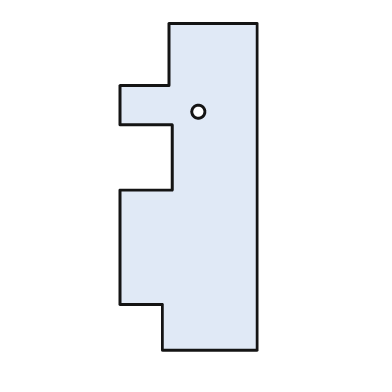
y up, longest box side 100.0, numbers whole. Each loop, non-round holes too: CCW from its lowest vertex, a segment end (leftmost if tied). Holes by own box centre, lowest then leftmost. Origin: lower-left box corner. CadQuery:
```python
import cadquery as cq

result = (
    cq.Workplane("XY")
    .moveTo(13.0, 0.0)
    .lineTo(42.0, 0.0)
    .lineTo(42.0, 100.0)
    .lineTo(15.0, 100.0)
    .lineTo(15.0, 81.0)
    .lineTo(0.0, 81.0)
    .lineTo(0.0, 69.0)
    .lineTo(16.0, 69.0)
    .lineTo(16.0, 49.0)
    .lineTo(0.0, 49.0)
    .lineTo(0.0, 14.0)
    .lineTo(13.0, 14.0)
    .close()
    .moveTo(24.0, 73.0)
    .circle(2.0)
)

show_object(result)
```